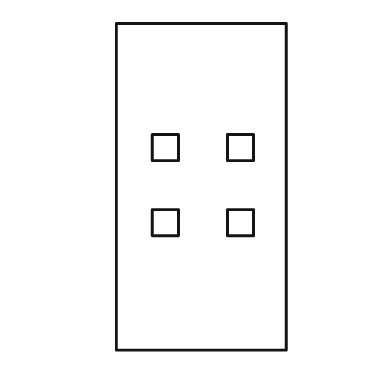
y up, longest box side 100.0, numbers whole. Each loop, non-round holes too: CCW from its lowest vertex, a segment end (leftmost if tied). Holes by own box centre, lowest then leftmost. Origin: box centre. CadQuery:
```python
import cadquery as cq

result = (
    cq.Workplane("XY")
    .moveTo(-26.0, -50.0)
    .lineTo(26.0, -50.0)
    .lineTo(26.0, 50.0)
    .lineTo(-26.0, 50.0)
    .close()
    .moveTo(-15.0, -15.0)
    .lineTo(-7.0, -15.0)
    .lineTo(-7.0, -7.0)
    .lineTo(-15.0, -7.0)
    .close()
    .moveTo(8.0, -15.0)
    .lineTo(16.0, -15.0)
    .lineTo(16.0, -7.0)
    .lineTo(8.0, -7.0)
    .close()
    .moveTo(-15.0, 8.0)
    .lineTo(-7.0, 8.0)
    .lineTo(-7.0, 16.0)
    .lineTo(-15.0, 16.0)
    .close()
    .moveTo(8.0, 8.0)
    .lineTo(16.0, 8.0)
    .lineTo(16.0, 16.0)
    .lineTo(8.0, 16.0)
    .close()
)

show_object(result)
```